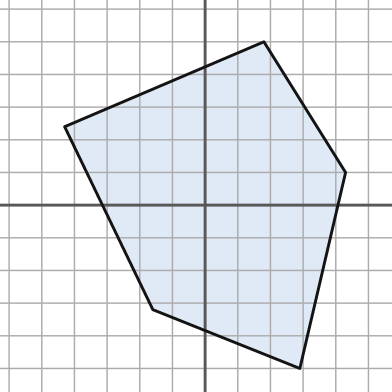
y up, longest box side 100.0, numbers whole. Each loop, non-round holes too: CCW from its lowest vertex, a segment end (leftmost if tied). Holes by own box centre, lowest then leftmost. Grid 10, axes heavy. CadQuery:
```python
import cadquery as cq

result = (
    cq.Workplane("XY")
    .moveTo(29.0, -50.0)
    .lineTo(43.0, 10.0)
    .lineTo(18.0, 50.0)
    .lineTo(-43.0, 24.0)
    .lineTo(-16.0, -32.0)
    .close()
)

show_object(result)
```